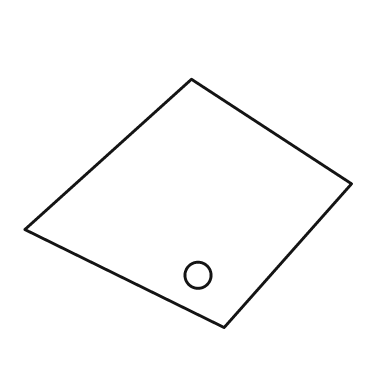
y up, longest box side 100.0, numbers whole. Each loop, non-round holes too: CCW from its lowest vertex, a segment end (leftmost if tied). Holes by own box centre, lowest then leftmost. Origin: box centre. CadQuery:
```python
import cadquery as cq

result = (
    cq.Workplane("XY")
    .moveTo(11.0, -38.0)
    .lineTo(50.0, 6.0)
    .lineTo(1.0, 38.0)
    .lineTo(-50.0, -8.0)
    .close()
    .moveTo(3.0, -22.0)
    .circle(4.0)
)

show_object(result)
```